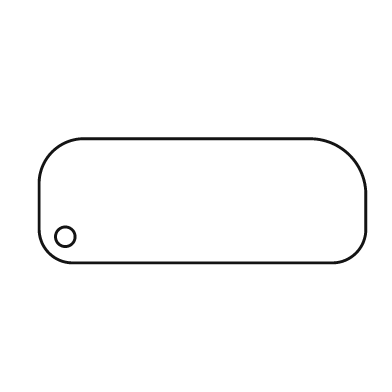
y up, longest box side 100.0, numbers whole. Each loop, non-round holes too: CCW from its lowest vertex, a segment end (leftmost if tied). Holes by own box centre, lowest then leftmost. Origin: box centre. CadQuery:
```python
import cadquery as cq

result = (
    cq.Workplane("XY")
    .moveTo(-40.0, -19.0)
    .lineTo(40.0, -19.0)
    .threePointArc((47.0, -16.0), (50.0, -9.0))
    .lineTo(50.0, 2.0)
    .threePointArc((45.0, 14.0), (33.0, 19.0))
    .lineTo(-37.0, 19.0)
    .threePointArc((-46.0, 15.0), (-50.0, 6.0))
    .lineTo(-50.0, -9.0)
    .threePointArc((-47.0, -16.0), (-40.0, -19.0))
    .close()
    .moveTo(-42.0, -11.0)
    .circle(3.0)
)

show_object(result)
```